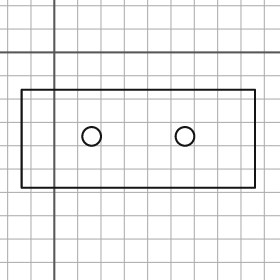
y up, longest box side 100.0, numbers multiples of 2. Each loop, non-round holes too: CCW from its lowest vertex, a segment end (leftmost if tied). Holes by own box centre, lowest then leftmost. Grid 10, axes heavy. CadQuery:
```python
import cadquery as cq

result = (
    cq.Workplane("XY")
    .moveTo(-14.0, -58.0)
    .lineTo(86.0, -58.0)
    .lineTo(86.0, -16.0)
    .lineTo(-14.0, -16.0)
    .close()
    .moveTo(16.0, -36.0)
    .circle(4.0)
    .moveTo(56.0, -36.0)
    .circle(4.0)
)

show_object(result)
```